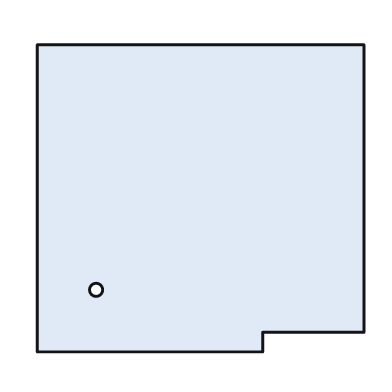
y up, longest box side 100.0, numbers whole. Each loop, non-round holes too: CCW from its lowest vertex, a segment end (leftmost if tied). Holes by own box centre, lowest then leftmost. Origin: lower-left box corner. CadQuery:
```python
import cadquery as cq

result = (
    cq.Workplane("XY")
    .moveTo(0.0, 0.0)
    .lineTo(69.0, 0.0)
    .lineTo(69.0, 6.0)
    .lineTo(100.0, 6.0)
    .lineTo(100.0, 94.0)
    .lineTo(0.0, 94.0)
    .close()
    .moveTo(18.0, 19.0)
    .circle(2.0)
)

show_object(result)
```